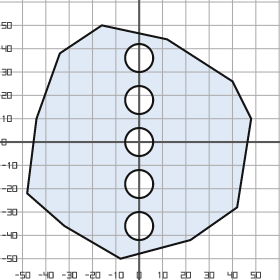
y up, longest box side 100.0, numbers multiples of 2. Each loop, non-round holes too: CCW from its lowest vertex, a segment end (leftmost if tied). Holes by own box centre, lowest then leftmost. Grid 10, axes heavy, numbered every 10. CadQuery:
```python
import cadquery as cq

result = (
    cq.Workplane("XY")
    .moveTo(-8.0, -50.0)
    .lineTo(22.0, -42.0)
    .lineTo(42.0, -28.0)
    .lineTo(48.0, 10.0)
    .lineTo(40.0, 26.0)
    .lineTo(12.0, 44.0)
    .lineTo(-16.0, 50.0)
    .lineTo(-34.0, 38.0)
    .lineTo(-44.0, 10.0)
    .lineTo(-48.0, -22.0)
    .lineTo(-32.0, -36.0)
    .close()
    .moveTo(0.0, -36.0)
    .circle(6.0)
    .moveTo(0.0, -18.0)
    .circle(6.0)
    .moveTo(0.0, 0.0)
    .circle(6.0)
    .moveTo(0.0, 18.0)
    .circle(6.0)
    .moveTo(0.0, 36.0)
    .circle(6.0)
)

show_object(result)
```